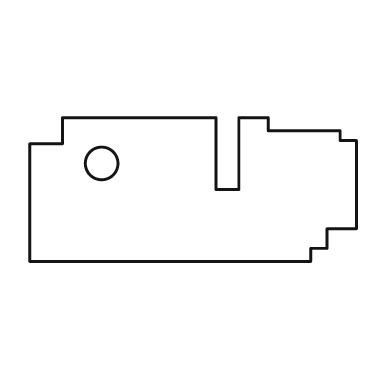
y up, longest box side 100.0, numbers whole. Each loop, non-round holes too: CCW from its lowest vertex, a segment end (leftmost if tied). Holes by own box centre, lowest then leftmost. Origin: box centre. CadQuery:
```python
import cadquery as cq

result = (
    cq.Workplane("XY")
    .moveTo(-50.0, -22.0)
    .lineTo(36.0, -22.0)
    .lineTo(36.0, -18.0)
    .lineTo(41.0, -18.0)
    .lineTo(41.0, -12.0)
    .lineTo(50.0, -12.0)
    .lineTo(50.0, 15.0)
    .lineTo(45.0, 15.0)
    .lineTo(45.0, 18.0)
    .lineTo(23.0, 18.0)
    .lineTo(23.0, 22.0)
    .lineTo(14.0, 22.0)
    .lineTo(14.0, 0.0)
    .lineTo(7.0, 0.0)
    .lineTo(7.0, 22.0)
    .lineTo(-40.0, 22.0)
    .lineTo(-40.0, 14.0)
    .lineTo(-50.0, 14.0)
    .close()
    .moveTo(-28.0, 8.0)
    .circle(5.0)
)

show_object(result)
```